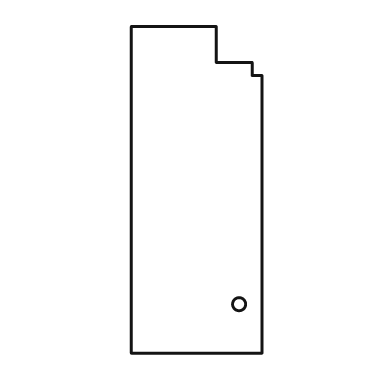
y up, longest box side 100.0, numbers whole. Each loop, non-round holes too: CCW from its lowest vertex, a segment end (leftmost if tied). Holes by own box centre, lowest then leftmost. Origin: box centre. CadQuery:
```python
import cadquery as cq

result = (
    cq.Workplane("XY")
    .moveTo(-20.0, -50.0)
    .lineTo(20.0, -50.0)
    .lineTo(20.0, 35.0)
    .lineTo(17.0, 35.0)
    .lineTo(17.0, 39.0)
    .lineTo(6.0, 39.0)
    .lineTo(6.0, 50.0)
    .lineTo(-20.0, 50.0)
    .close()
    .moveTo(13.0, -35.0)
    .circle(2.0)
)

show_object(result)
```